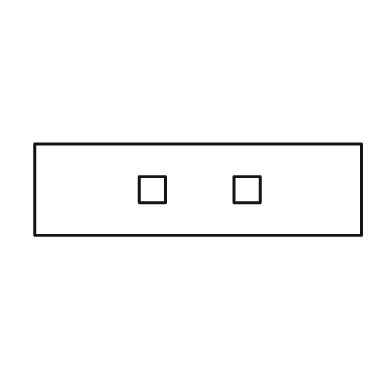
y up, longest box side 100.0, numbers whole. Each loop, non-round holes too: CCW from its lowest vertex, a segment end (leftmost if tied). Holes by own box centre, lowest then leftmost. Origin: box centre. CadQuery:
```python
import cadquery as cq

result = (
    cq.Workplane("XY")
    .moveTo(-50.0, -14.0)
    .lineTo(50.0, -14.0)
    .lineTo(50.0, 14.0)
    .lineTo(-50.0, 14.0)
    .close()
    .moveTo(-18.0, -4.0)
    .lineTo(-10.0, -4.0)
    .lineTo(-10.0, 4.0)
    .lineTo(-18.0, 4.0)
    .close()
    .moveTo(11.0, -4.0)
    .lineTo(19.0, -4.0)
    .lineTo(19.0, 4.0)
    .lineTo(11.0, 4.0)
    .close()
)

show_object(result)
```